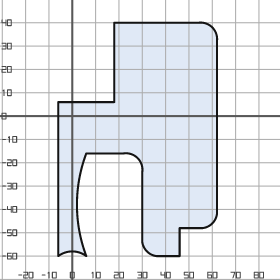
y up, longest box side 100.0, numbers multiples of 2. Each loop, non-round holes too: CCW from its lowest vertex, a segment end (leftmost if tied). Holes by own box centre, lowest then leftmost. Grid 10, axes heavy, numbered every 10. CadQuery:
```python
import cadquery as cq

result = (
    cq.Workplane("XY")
    .moveTo(-6.0, -60.0)
    .threePointArc((0.0, -58.0), (6.0, -60.0))
    .threePointArc((2.0, -38.0), (6.0, -16.0))
    .lineTo(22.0, -16.0)
    .threePointArc((28.0, -18.0), (30.0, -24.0))
    .lineTo(30.0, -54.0)
    .threePointArc((32.0, -58.0), (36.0, -60.0))
    .lineTo(46.0, -60.0)
    .lineTo(46.0, -48.0)
    .lineTo(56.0, -48.0)
    .threePointArc((60.0, -46.0), (62.0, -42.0))
    .lineTo(62.0, 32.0)
    .threePointArc((60.0, 38.0), (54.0, 40.0))
    .lineTo(18.0, 40.0)
    .lineTo(18.0, 6.0)
    .lineTo(-6.0, 6.0)
    .close()
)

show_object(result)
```